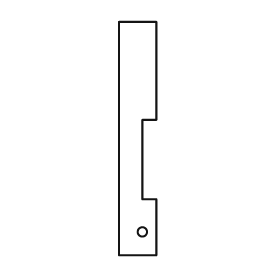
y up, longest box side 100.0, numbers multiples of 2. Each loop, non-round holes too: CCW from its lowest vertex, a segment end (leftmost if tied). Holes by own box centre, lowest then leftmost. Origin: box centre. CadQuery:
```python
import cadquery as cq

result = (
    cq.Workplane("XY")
    .moveTo(-8.0, -50.0)
    .lineTo(8.0, -50.0)
    .lineTo(8.0, -26.0)
    .lineTo(2.0, -26.0)
    .lineTo(2.0, 8.0)
    .lineTo(8.0, 8.0)
    .lineTo(8.0, 50.0)
    .lineTo(-8.0, 50.0)
    .close()
    .moveTo(2.0, -40.0)
    .circle(2.0)
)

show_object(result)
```